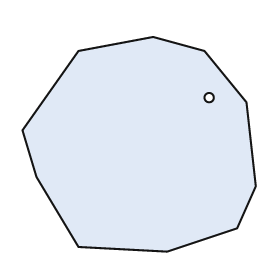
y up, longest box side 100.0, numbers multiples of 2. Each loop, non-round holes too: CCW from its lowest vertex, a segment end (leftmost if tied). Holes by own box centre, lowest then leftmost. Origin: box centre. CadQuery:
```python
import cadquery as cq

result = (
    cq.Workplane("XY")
    .moveTo(12.0, -46.0)
    .lineTo(42.0, -36.0)
    .lineTo(50.0, -18.0)
    .lineTo(46.0, 18.0)
    .lineTo(28.0, 40.0)
    .lineTo(6.0, 46.0)
    .lineTo(-26.0, 40.0)
    .lineTo(-50.0, 6.0)
    .lineTo(-44.0, -14.0)
    .lineTo(-26.0, -44.0)
    .close()
    .moveTo(30.0, 20.0)
    .circle(2.0)
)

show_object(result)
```